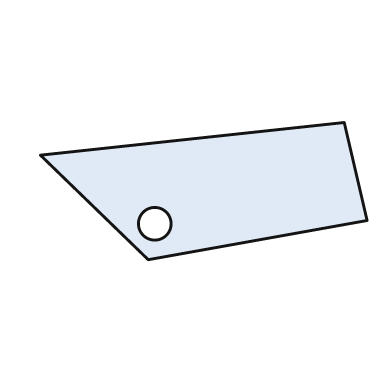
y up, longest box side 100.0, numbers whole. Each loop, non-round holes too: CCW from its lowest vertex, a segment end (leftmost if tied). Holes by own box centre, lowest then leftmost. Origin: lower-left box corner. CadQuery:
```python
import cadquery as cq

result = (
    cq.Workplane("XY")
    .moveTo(33.0, 0.0)
    .lineTo(100.0, 12.0)
    .lineTo(93.0, 42.0)
    .lineTo(0.0, 32.0)
    .close()
    .moveTo(35.0, 11.0)
    .circle(5.0)
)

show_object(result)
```